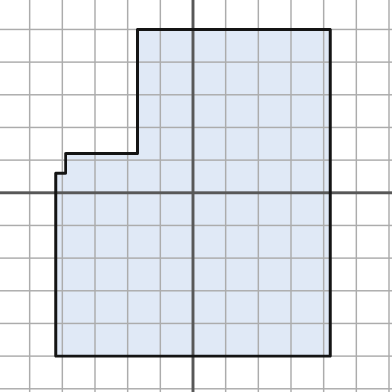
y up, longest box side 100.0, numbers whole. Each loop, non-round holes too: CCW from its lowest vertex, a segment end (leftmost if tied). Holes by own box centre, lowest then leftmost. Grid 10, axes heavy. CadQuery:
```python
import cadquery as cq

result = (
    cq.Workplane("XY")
    .moveTo(-42.0, -50.0)
    .lineTo(42.0, -50.0)
    .lineTo(42.0, 50.0)
    .lineTo(-17.0, 50.0)
    .lineTo(-17.0, 12.0)
    .lineTo(-39.0, 12.0)
    .lineTo(-39.0, 6.0)
    .lineTo(-42.0, 6.0)
    .close()
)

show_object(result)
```